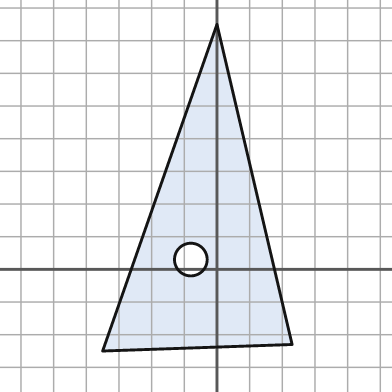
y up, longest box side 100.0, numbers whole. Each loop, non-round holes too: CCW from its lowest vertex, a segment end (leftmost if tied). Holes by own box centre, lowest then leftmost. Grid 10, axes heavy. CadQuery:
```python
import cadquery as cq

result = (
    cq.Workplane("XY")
    .moveTo(-35.0, -25.0)
    .lineTo(23.0, -23.0)
    .lineTo(0.0, 75.0)
    .close()
    .moveTo(-8.0, 3.0)
    .circle(5.0)
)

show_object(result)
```